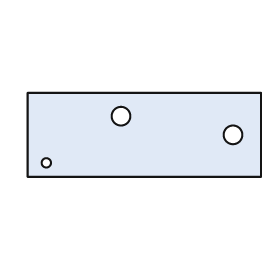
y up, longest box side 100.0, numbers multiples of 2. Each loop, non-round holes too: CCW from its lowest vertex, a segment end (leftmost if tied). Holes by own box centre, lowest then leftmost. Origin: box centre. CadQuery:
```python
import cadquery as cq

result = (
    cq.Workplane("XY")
    .moveTo(-50.0, -18.0)
    .lineTo(50.0, -18.0)
    .lineTo(50.0, 18.0)
    .lineTo(-50.0, 18.0)
    .close()
    .moveTo(-42.0, -12.0)
    .circle(2.0)
    .moveTo(38.0, 0.0)
    .circle(4.0)
    .moveTo(-10.0, 8.0)
    .circle(4.0)
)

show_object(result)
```